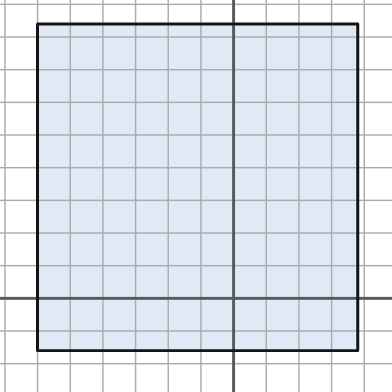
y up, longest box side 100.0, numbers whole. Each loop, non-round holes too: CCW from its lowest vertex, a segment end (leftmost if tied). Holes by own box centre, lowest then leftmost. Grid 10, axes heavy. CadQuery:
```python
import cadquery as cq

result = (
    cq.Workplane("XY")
    .moveTo(-60.0, -16.0)
    .lineTo(38.0, -16.0)
    .lineTo(38.0, 84.0)
    .lineTo(-60.0, 84.0)
    .close()
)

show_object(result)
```